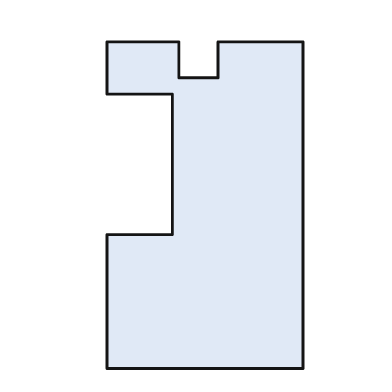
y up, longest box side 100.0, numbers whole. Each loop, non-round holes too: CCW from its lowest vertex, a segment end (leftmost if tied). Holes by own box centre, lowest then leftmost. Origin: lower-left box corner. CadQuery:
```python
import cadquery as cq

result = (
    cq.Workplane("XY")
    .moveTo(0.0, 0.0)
    .lineTo(60.0, 0.0)
    .lineTo(60.0, 100.0)
    .lineTo(34.0, 100.0)
    .lineTo(34.0, 89.0)
    .lineTo(22.0, 89.0)
    .lineTo(22.0, 100.0)
    .lineTo(0.0, 100.0)
    .lineTo(0.0, 84.0)
    .lineTo(20.0, 84.0)
    .lineTo(20.0, 41.0)
    .lineTo(0.0, 41.0)
    .close()
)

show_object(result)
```